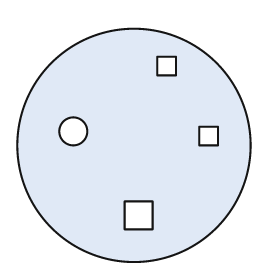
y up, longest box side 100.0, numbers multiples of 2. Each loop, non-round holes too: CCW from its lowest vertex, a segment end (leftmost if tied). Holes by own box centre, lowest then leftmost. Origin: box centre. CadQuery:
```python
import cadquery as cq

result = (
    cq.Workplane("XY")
    .moveTo(0.0, 0.0)
    .circle(50.0)
    .moveTo(-4.0, -36.0)
    .lineTo(8.0, -36.0)
    .lineTo(8.0, -24.0)
    .lineTo(-4.0, -24.0)
    .close()
    .moveTo(28.0, 0.0)
    .lineTo(36.0, 0.0)
    .lineTo(36.0, 8.0)
    .lineTo(28.0, 8.0)
    .close()
    .moveTo(-26.0, 6.0)
    .circle(6.0)
    .moveTo(10.0, 30.0)
    .lineTo(18.0, 30.0)
    .lineTo(18.0, 38.0)
    .lineTo(10.0, 38.0)
    .close()
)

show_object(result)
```